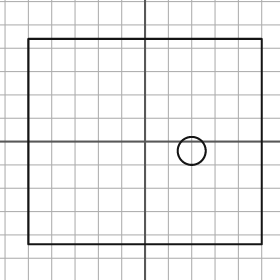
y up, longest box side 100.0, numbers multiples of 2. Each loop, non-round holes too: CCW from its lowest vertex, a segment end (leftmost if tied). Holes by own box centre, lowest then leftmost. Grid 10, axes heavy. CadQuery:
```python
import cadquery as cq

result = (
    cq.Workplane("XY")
    .moveTo(-50.0, -44.0)
    .lineTo(50.0, -44.0)
    .lineTo(50.0, 44.0)
    .lineTo(-50.0, 44.0)
    .close()
    .moveTo(20.0, -4.0)
    .circle(6.0)
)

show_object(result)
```